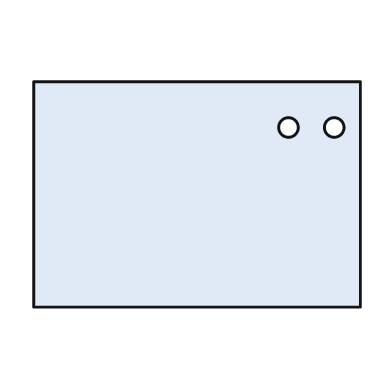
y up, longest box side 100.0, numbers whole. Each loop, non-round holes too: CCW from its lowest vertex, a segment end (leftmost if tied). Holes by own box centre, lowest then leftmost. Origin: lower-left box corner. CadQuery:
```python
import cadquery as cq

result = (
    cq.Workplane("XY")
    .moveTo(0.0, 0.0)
    .lineTo(100.0, 0.0)
    .lineTo(100.0, 69.0)
    .lineTo(0.0, 69.0)
    .close()
    .moveTo(78.0, 55.0)
    .circle(3.0)
    .moveTo(92.0, 55.0)
    .circle(3.0)
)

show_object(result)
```